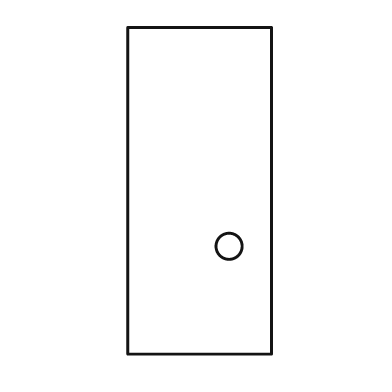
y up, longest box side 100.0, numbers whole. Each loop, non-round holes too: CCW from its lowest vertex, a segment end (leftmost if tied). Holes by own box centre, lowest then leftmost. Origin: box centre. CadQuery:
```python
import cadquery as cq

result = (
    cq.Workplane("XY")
    .moveTo(-22.0, -50.0)
    .lineTo(22.0, -50.0)
    .lineTo(22.0, 50.0)
    .lineTo(-22.0, 50.0)
    .close()
    .moveTo(9.0, -17.0)
    .circle(4.0)
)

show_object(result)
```